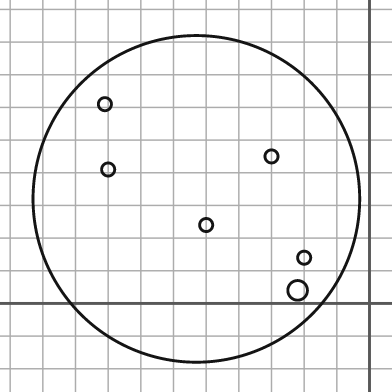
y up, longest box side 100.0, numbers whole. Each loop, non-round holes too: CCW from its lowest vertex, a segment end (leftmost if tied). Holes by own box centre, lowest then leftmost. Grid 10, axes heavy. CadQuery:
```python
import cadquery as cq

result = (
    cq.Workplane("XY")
    .moveTo(-53.0, 32.0)
    .circle(50.0)
    .moveTo(-22.0, 4.0)
    .circle(3.0)
    .moveTo(-20.0, 14.0)
    .circle(2.0)
    .moveTo(-50.0, 24.0)
    .circle(2.0)
    .moveTo(-80.0, 41.0)
    .circle(2.0)
    .moveTo(-30.0, 45.0)
    .circle(2.0)
    .moveTo(-81.0, 61.0)
    .circle(2.0)
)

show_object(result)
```